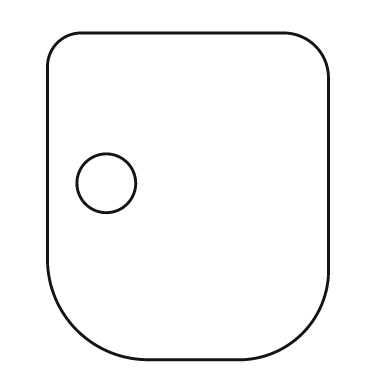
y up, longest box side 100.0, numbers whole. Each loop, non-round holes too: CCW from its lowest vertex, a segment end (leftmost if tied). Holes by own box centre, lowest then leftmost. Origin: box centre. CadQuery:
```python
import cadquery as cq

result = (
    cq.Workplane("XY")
    .moveTo(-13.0, -50.0)
    .lineTo(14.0, -50.0)
    .threePointArc((35.0, -42.0), (43.0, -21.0))
    .lineTo(43.0, 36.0)
    .threePointArc((39.0, 46.0), (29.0, 50.0))
    .lineTo(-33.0, 50.0)
    .threePointArc((-40.0, 47.0), (-43.0, 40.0))
    .lineTo(-43.0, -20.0)
    .threePointArc((-34.0, -41.0), (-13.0, -50.0))
    .close()
    .moveTo(-25.0, 4.0)
    .circle(9.0)
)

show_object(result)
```